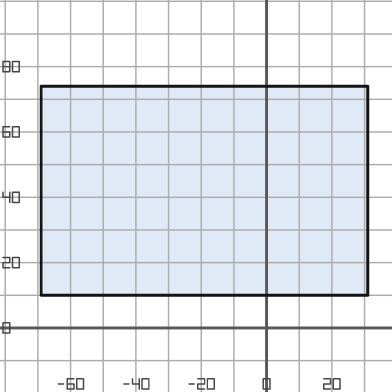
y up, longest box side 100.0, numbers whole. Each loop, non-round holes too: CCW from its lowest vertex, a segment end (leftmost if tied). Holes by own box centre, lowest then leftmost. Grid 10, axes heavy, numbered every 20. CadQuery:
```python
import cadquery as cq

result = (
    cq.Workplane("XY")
    .moveTo(-69.0, 10.0)
    .lineTo(31.0, 10.0)
    .lineTo(31.0, 74.0)
    .lineTo(-69.0, 74.0)
    .close()
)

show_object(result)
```